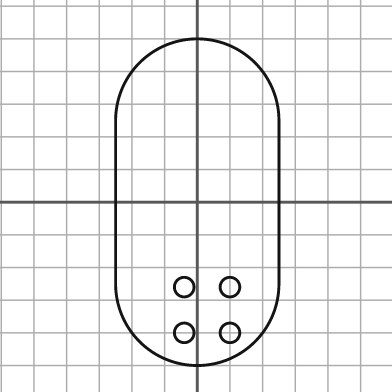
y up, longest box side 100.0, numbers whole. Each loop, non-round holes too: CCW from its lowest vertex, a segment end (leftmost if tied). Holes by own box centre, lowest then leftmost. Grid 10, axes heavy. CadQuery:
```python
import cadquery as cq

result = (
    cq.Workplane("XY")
    .moveTo(-25.0, -25.0)
    .threePointArc((0.0, -50.0), (25.0, -25.0))
    .lineTo(25.0, 25.0)
    .threePointArc((0.0, 50.0), (-25.0, 25.0))
    .close()
    .moveTo(-4.0, -40.0)
    .circle(3.0)
    .moveTo(10.0, -40.0)
    .circle(3.0)
    .moveTo(-4.0, -26.0)
    .circle(3.0)
    .moveTo(10.0, -26.0)
    .circle(3.0)
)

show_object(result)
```